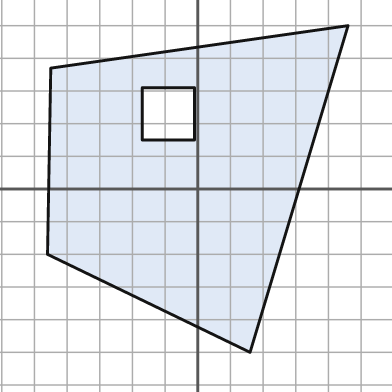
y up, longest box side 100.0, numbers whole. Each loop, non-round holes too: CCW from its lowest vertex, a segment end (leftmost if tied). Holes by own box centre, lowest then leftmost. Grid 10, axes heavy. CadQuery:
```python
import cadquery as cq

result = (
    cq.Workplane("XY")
    .moveTo(16.0, -50.0)
    .lineTo(46.0, 50.0)
    .lineTo(-45.0, 37.0)
    .lineTo(-46.0, -20.0)
    .close()
    .moveTo(-17.0, 15.0)
    .lineTo(-1.0, 15.0)
    .lineTo(-1.0, 31.0)
    .lineTo(-17.0, 31.0)
    .close()
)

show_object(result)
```